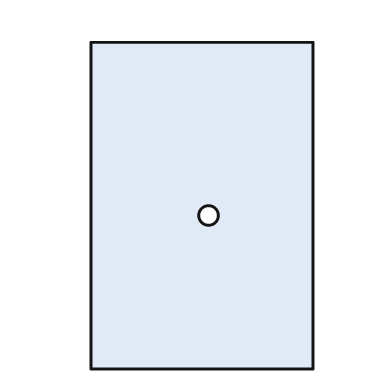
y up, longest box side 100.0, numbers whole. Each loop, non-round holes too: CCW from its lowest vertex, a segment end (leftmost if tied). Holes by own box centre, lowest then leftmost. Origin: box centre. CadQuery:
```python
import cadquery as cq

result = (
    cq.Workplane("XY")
    .moveTo(-34.0, -50.0)
    .lineTo(34.0, -50.0)
    .lineTo(34.0, 50.0)
    .lineTo(-34.0, 50.0)
    .close()
    .moveTo(2.0, -3.0)
    .circle(3.0)
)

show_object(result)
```